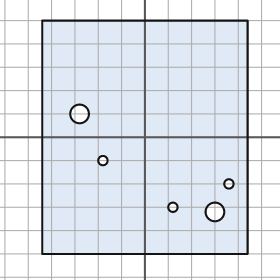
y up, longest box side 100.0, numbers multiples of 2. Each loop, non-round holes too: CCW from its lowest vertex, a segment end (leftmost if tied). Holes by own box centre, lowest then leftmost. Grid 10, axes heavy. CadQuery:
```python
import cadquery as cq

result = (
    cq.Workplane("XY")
    .moveTo(-44.0, -50.0)
    .lineTo(44.0, -50.0)
    .lineTo(44.0, 50.0)
    .lineTo(-44.0, 50.0)
    .close()
    .moveTo(30.0, -32.0)
    .circle(4.0)
    .moveTo(12.0, -30.0)
    .circle(2.0)
    .moveTo(36.0, -20.0)
    .circle(2.0)
    .moveTo(-18.0, -10.0)
    .circle(2.0)
    .moveTo(-28.0, 10.0)
    .circle(4.0)
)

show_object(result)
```